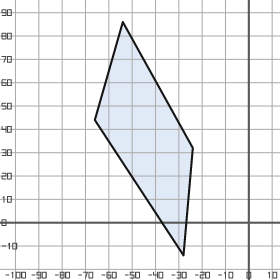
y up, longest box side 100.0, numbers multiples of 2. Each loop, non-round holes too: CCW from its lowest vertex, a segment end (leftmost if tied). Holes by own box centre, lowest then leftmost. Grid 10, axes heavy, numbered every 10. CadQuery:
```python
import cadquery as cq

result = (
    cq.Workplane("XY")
    .moveTo(-28.0, -14.0)
    .lineTo(-24.0, 32.0)
    .lineTo(-54.0, 86.0)
    .lineTo(-66.0, 44.0)
    .close()
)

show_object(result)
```